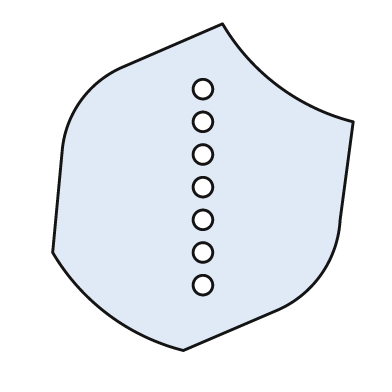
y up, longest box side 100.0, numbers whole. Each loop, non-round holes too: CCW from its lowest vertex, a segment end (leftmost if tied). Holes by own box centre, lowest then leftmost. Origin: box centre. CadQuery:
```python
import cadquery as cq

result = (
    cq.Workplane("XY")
    .moveTo(-6.0, -50.0)
    .lineTo(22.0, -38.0)
    .threePointArc((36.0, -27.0), (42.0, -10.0))
    .lineTo(46.0, 20.0)
    .threePointArc((23.0, 31.0), (6.0, 50.0))
    .lineTo(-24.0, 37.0)
    .threePointArc((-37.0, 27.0), (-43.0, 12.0))
    .lineTo(-46.0, -20.0)
    .threePointArc((-29.0, -39.0), (-6.0, -50.0))
    .close()
    .moveTo(0.0, -30.0)
    .circle(3.0)
    .moveTo(0.0, -20.0)
    .circle(3.0)
    .moveTo(0.0, -10.0)
    .circle(3.0)
    .moveTo(0.0, 0.0)
    .circle(3.0)
    .moveTo(0.0, 10.0)
    .circle(3.0)
    .moveTo(0.0, 20.0)
    .circle(3.0)
    .moveTo(0.0, 30.0)
    .circle(3.0)
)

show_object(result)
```